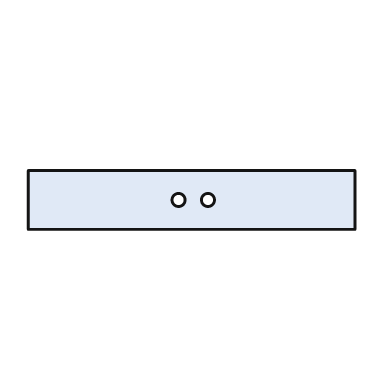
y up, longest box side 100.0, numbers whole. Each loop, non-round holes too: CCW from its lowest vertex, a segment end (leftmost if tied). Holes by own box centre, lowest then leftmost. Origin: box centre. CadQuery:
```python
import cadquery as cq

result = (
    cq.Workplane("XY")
    .moveTo(-50.0, -9.0)
    .lineTo(50.0, -9.0)
    .lineTo(50.0, 9.0)
    .lineTo(-50.0, 9.0)
    .close()
    .moveTo(-4.0, 0.0)
    .circle(2.0)
    .moveTo(5.0, 0.0)
    .circle(2.0)
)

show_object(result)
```